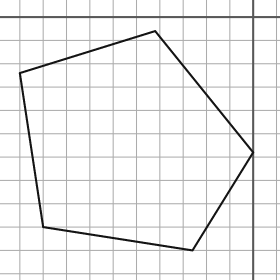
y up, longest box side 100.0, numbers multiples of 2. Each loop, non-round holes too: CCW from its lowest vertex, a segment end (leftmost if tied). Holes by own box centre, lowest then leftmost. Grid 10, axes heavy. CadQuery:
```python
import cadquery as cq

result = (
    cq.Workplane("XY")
    .moveTo(-26.0, -100.0)
    .lineTo(0.0, -58.0)
    .lineTo(-42.0, -6.0)
    .lineTo(-100.0, -24.0)
    .lineTo(-90.0, -90.0)
    .close()
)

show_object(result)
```